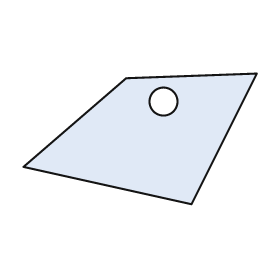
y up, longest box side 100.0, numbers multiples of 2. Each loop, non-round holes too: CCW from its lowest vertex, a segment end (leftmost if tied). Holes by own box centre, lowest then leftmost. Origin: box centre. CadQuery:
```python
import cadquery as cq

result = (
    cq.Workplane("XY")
    .moveTo(22.0, -28.0)
    .lineTo(50.0, 28.0)
    .lineTo(-6.0, 26.0)
    .lineTo(-50.0, -12.0)
    .close()
    .moveTo(10.0, 16.0)
    .circle(6.0)
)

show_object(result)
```